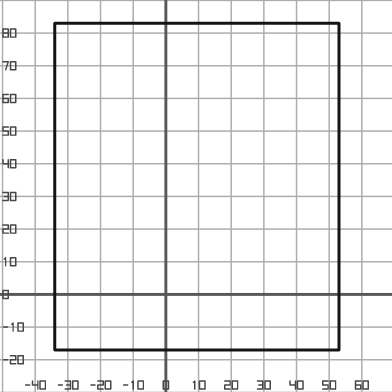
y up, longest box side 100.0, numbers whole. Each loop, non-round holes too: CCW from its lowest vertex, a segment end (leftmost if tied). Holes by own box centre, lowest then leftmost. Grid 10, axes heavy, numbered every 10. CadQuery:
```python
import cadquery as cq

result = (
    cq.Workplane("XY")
    .moveTo(-34.0, -17.0)
    .lineTo(53.0, -17.0)
    .lineTo(53.0, 83.0)
    .lineTo(-34.0, 83.0)
    .close()
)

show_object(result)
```